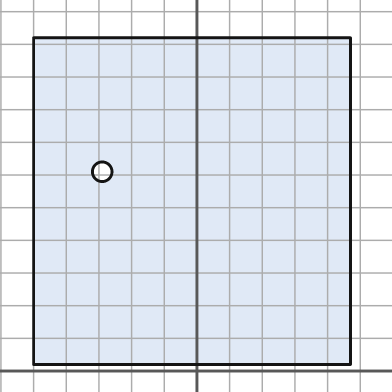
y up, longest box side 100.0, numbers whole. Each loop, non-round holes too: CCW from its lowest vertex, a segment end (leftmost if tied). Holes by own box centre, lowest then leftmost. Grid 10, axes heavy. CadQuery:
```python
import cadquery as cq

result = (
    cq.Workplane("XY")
    .moveTo(-50.0, 2.0)
    .lineTo(47.0, 2.0)
    .lineTo(47.0, 102.0)
    .lineTo(-50.0, 102.0)
    .close()
    .moveTo(-29.0, 61.0)
    .circle(3.0)
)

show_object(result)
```